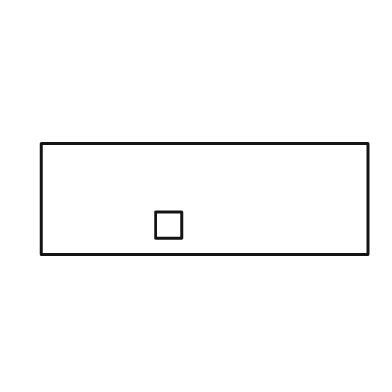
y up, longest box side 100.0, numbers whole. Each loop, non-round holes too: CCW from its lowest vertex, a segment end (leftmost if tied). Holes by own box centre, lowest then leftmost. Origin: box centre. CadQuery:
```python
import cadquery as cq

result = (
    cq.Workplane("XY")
    .moveTo(-50.0, -17.0)
    .lineTo(50.0, -17.0)
    .lineTo(50.0, 17.0)
    .lineTo(-50.0, 17.0)
    .close()
    .moveTo(-15.0, -12.0)
    .lineTo(-7.0, -12.0)
    .lineTo(-7.0, -4.0)
    .lineTo(-15.0, -4.0)
    .close()
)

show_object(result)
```